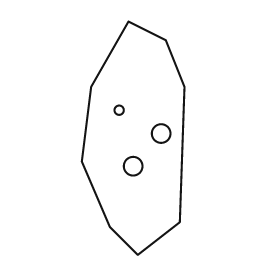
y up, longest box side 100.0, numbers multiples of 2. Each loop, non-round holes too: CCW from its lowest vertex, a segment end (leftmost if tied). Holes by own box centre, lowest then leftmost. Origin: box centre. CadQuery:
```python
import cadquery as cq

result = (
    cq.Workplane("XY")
    .moveTo(2.0, -50.0)
    .lineTo(20.0, -36.0)
    .lineTo(22.0, 22.0)
    .lineTo(14.0, 42.0)
    .lineTo(-2.0, 50.0)
    .lineTo(-18.0, 22.0)
    .lineTo(-22.0, -10.0)
    .lineTo(-10.0, -38.0)
    .close()
    .moveTo(0.0, -12.0)
    .circle(4.0)
    .moveTo(12.0, 2.0)
    .circle(4.0)
    .moveTo(-6.0, 12.0)
    .circle(2.0)
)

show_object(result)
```